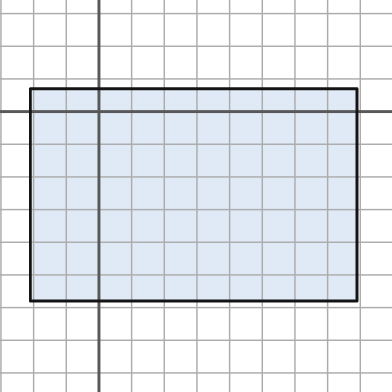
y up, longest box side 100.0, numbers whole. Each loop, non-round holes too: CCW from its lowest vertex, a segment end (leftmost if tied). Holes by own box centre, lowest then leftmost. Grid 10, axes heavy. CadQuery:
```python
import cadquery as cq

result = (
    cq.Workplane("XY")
    .moveTo(-21.0, -58.0)
    .lineTo(79.0, -58.0)
    .lineTo(79.0, 7.0)
    .lineTo(-21.0, 7.0)
    .close()
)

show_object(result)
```